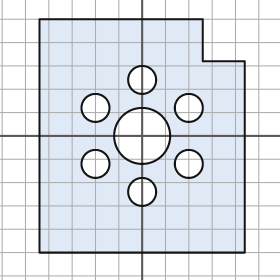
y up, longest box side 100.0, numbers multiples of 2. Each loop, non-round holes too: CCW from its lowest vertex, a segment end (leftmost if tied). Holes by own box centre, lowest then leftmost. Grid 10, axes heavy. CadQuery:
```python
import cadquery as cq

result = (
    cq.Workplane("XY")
    .moveTo(-44.0, -50.0)
    .lineTo(44.0, -50.0)
    .lineTo(44.0, 32.0)
    .lineTo(26.0, 32.0)
    .lineTo(26.0, 50.0)
    .lineTo(-44.0, 50.0)
    .close()
    .moveTo(0.0, -24.0)
    .circle(6.0)
    .moveTo(-20.0, -12.0)
    .circle(6.0)
    .moveTo(20.0, -12.0)
    .circle(6.0)
    .moveTo(0.0, 0.0)
    .circle(12.0)
    .moveTo(-20.0, 12.0)
    .circle(6.0)
    .moveTo(20.0, 12.0)
    .circle(6.0)
    .moveTo(0.0, 24.0)
    .circle(6.0)
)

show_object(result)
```